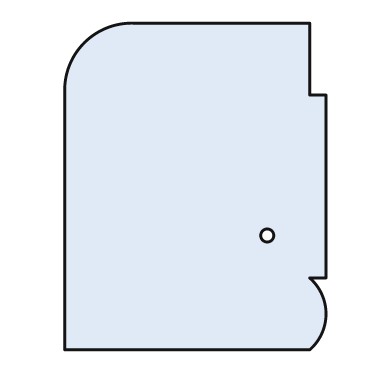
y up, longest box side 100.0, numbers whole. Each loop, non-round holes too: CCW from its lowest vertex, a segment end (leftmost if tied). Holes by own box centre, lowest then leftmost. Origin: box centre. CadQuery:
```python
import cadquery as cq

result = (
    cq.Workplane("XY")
    .moveTo(-40.0, -50.0)
    .lineTo(35.0, -50.0)
    .threePointArc((40.0, -39.0), (35.0, -28.0))
    .lineTo(40.0, -28.0)
    .lineTo(40.0, 28.0)
    .lineTo(35.0, 28.0)
    .lineTo(35.0, 50.0)
    .lineTo(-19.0, 50.0)
    .threePointArc((-34.0, 44.0), (-40.0, 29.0))
    .close()
    .moveTo(22.0, -15.0)
    .circle(2.0)
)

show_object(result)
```